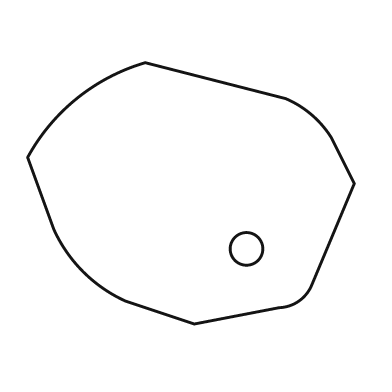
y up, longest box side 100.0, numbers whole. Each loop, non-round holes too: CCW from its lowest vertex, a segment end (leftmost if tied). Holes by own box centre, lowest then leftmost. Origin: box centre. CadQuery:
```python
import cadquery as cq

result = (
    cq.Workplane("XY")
    .moveTo(1.0, -40.0)
    .lineTo(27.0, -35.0)
    .threePointArc((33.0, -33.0), (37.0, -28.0))
    .lineTo(50.0, 3.0)
    .lineTo(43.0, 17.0)
    .threePointArc((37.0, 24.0), (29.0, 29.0))
    .lineTo(-14.0, 40.0)
    .threePointArc((-35.0, 29.0), (-50.0, 11.0))
    .lineTo(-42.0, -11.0)
    .threePointArc((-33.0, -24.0), (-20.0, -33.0))
    .close()
    .moveTo(17.0, -17.0)
    .circle(5.0)
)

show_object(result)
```